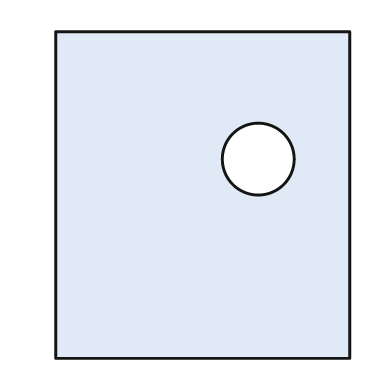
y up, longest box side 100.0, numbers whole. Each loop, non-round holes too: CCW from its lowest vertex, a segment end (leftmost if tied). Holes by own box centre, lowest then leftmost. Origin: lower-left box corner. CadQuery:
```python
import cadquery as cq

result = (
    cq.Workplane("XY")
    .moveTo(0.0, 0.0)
    .lineTo(90.0, 0.0)
    .lineTo(90.0, 100.0)
    .lineTo(0.0, 100.0)
    .close()
    .moveTo(62.0, 61.0)
    .circle(11.0)
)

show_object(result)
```